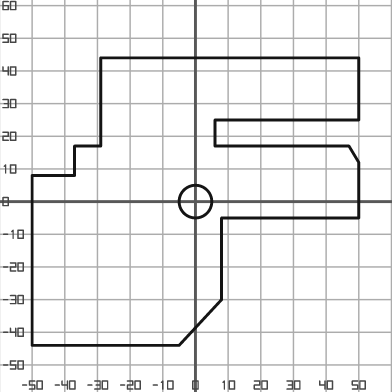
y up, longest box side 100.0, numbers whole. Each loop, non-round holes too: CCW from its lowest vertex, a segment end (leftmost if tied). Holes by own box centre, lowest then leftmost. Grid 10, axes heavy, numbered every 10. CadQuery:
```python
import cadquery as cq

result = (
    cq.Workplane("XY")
    .moveTo(-50.0, -44.0)
    .lineTo(-5.0, -44.0)
    .lineTo(8.0, -30.0)
    .lineTo(8.0, -5.0)
    .lineTo(50.0, -5.0)
    .lineTo(50.0, 12.0)
    .lineTo(47.0, 17.0)
    .lineTo(6.0, 17.0)
    .lineTo(6.0, 25.0)
    .lineTo(50.0, 25.0)
    .lineTo(50.0, 44.0)
    .lineTo(-29.0, 44.0)
    .lineTo(-29.0, 17.0)
    .lineTo(-37.0, 17.0)
    .lineTo(-37.0, 8.0)
    .lineTo(-50.0, 8.0)
    .close()
    .moveTo(0.0, 0.0)
    .circle(5.0)
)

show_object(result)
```